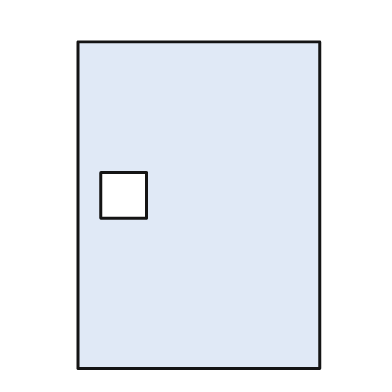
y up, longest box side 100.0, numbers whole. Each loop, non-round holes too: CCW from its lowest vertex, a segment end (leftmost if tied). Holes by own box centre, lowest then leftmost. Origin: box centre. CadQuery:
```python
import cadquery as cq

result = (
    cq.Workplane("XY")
    .moveTo(-37.0, -50.0)
    .lineTo(37.0, -50.0)
    .lineTo(37.0, 50.0)
    .lineTo(-37.0, 50.0)
    .close()
    .moveTo(-30.0, -4.0)
    .lineTo(-16.0, -4.0)
    .lineTo(-16.0, 10.0)
    .lineTo(-30.0, 10.0)
    .close()
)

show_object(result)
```